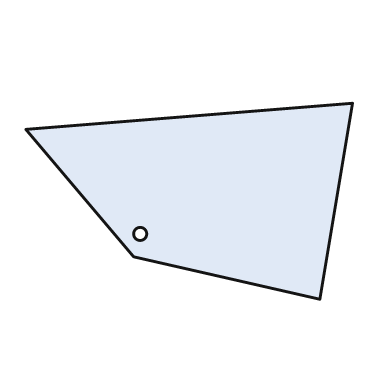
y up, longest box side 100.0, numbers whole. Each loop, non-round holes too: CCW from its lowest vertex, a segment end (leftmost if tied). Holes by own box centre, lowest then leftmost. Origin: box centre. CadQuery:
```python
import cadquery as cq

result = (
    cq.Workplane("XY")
    .moveTo(40.0, -30.0)
    .lineTo(50.0, 30.0)
    .lineTo(-50.0, 22.0)
    .lineTo(-17.0, -17.0)
    .close()
    .moveTo(-15.0, -10.0)
    .circle(2.0)
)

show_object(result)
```